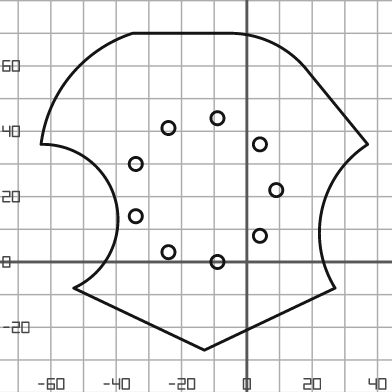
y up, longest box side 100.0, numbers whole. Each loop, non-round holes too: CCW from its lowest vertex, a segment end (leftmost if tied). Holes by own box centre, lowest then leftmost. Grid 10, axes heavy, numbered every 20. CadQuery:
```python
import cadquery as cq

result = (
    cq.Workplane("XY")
    .moveTo(-13.0, -27.0)
    .lineTo(27.0, -8.0)
    .threePointArc((23.0, 16.0), (37.0, 36.0))
    .lineTo(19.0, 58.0)
    .threePointArc((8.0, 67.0), (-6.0, 70.0))
    .lineTo(-35.0, 70.0)
    .threePointArc((-54.0, 57.0), (-63.0, 36.0))
    .threePointArc((-40.0, 18.0), (-53.0, -8.0))
    .close()
    .moveTo(-9.0, 0.0)
    .circle(2.0)
    .moveTo(-24.0, 3.0)
    .circle(2.0)
    .moveTo(4.0, 8.0)
    .circle(2.0)
    .moveTo(-34.0, 14.0)
    .circle(2.0)
    .moveTo(9.0, 22.0)
    .circle(2.0)
    .moveTo(-34.0, 30.0)
    .circle(2.0)
    .moveTo(4.0, 36.0)
    .circle(2.0)
    .moveTo(-24.0, 41.0)
    .circle(2.0)
    .moveTo(-9.0, 44.0)
    .circle(2.0)
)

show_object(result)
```